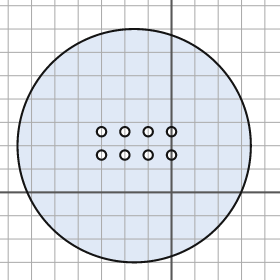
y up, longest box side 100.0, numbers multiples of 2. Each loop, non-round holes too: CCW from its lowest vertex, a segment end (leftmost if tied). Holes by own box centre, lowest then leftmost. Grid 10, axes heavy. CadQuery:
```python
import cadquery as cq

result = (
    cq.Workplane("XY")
    .moveTo(-16.0, 20.0)
    .circle(50.0)
    .moveTo(-30.0, 16.0)
    .circle(2.0)
    .moveTo(-20.0, 16.0)
    .circle(2.0)
    .moveTo(-10.0, 16.0)
    .circle(2.0)
    .moveTo(0.0, 16.0)
    .circle(2.0)
    .moveTo(-30.0, 26.0)
    .circle(2.0)
    .moveTo(-20.0, 26.0)
    .circle(2.0)
    .moveTo(-10.0, 26.0)
    .circle(2.0)
    .moveTo(0.0, 26.0)
    .circle(2.0)
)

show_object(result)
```